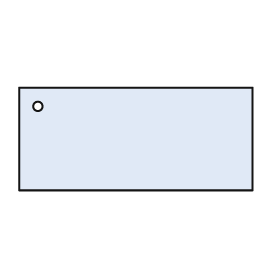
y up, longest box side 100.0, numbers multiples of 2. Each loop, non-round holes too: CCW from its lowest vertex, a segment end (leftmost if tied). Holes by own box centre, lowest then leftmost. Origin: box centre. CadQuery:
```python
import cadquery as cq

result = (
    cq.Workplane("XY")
    .moveTo(-50.0, -22.0)
    .lineTo(50.0, -22.0)
    .lineTo(50.0, 22.0)
    .lineTo(-50.0, 22.0)
    .close()
    .moveTo(-42.0, 14.0)
    .circle(2.0)
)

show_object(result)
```